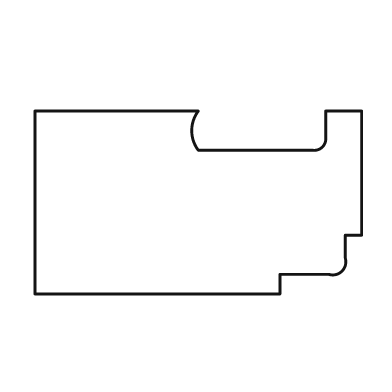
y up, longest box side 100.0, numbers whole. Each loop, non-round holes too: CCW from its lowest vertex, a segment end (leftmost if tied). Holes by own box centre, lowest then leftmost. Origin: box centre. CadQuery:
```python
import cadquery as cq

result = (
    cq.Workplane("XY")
    .moveTo(-50.0, -28.0)
    .lineTo(25.0, -28.0)
    .lineTo(25.0, -22.0)
    .lineTo(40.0, -22.0)
    .threePointArc((44.0, -21.0), (45.0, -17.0))
    .lineTo(45.0, -10.0)
    .lineTo(50.0, -10.0)
    .lineTo(50.0, 28.0)
    .lineTo(39.0, 28.0)
    .lineTo(39.0, 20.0)
    .threePointArc((38.0, 17.0), (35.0, 16.0))
    .lineTo(0.0, 16.0)
    .threePointArc((-2.0, 22.0), (0.0, 28.0))
    .lineTo(-50.0, 28.0)
    .close()
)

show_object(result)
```